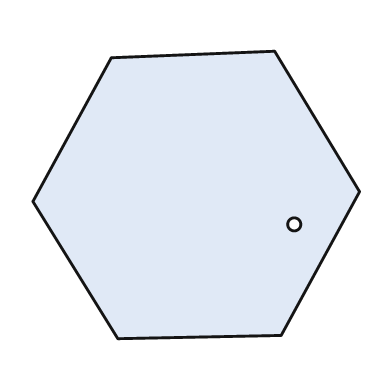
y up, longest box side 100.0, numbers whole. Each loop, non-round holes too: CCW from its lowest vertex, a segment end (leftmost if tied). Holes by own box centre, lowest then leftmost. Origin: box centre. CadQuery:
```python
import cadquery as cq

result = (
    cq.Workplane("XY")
    .moveTo(-24.0, -44.0)
    .lineTo(26.0, -43.0)
    .lineTo(50.0, 1.0)
    .lineTo(24.0, 44.0)
    .lineTo(-26.0, 42.0)
    .lineTo(-50.0, -2.0)
    .close()
    .moveTo(30.0, -9.0)
    .circle(2.0)
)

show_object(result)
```